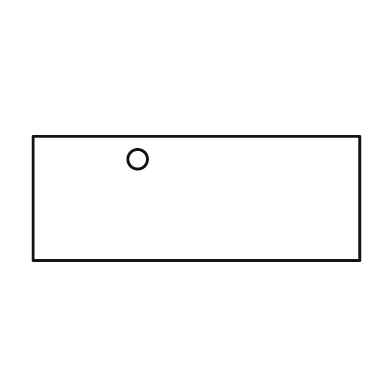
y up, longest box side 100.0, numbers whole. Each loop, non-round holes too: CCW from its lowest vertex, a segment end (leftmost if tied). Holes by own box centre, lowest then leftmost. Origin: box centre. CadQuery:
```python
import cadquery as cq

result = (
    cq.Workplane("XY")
    .moveTo(-50.0, -19.0)
    .lineTo(50.0, -19.0)
    .lineTo(50.0, 19.0)
    .lineTo(-50.0, 19.0)
    .close()
    .moveTo(-18.0, 12.0)
    .circle(3.0)
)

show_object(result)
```